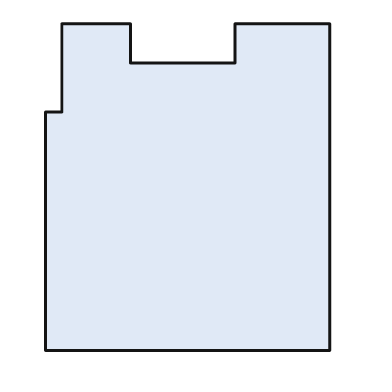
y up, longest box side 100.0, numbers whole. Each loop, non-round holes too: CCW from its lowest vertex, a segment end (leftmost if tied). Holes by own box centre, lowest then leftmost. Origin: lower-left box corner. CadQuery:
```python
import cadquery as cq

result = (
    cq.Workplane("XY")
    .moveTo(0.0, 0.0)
    .lineTo(87.0, 0.0)
    .lineTo(87.0, 100.0)
    .lineTo(58.0, 100.0)
    .lineTo(58.0, 88.0)
    .lineTo(26.0, 88.0)
    .lineTo(26.0, 100.0)
    .lineTo(5.0, 100.0)
    .lineTo(5.0, 73.0)
    .lineTo(0.0, 73.0)
    .close()
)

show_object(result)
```